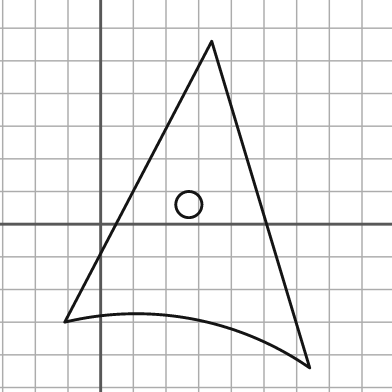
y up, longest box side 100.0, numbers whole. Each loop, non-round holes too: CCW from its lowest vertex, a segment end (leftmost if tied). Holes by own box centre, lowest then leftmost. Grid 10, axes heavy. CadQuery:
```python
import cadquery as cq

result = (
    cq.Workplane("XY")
    .moveTo(64.0, -44.0)
    .lineTo(34.0, 56.0)
    .lineTo(-11.0, -30.0)
    .threePointArc((28.0, -29.0), (64.0, -44.0))
    .close()
    .moveTo(27.0, 6.0)
    .circle(4.0)
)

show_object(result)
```